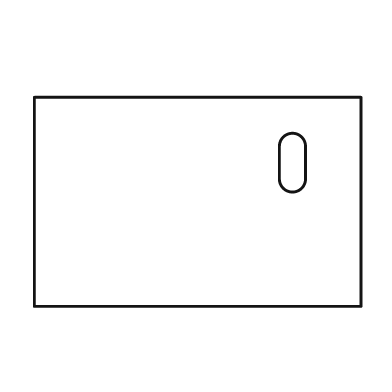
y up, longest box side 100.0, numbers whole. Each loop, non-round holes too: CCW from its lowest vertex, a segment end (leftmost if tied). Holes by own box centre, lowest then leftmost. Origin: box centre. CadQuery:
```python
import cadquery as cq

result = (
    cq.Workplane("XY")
    .moveTo(-50.0, -32.0)
    .lineTo(50.0, -32.0)
    .lineTo(50.0, 32.0)
    .lineTo(-50.0, 32.0)
    .close()
    .moveTo(25.0, 7.0)
    .threePointArc((29.0, 3.0), (33.0, 7.0))
    .lineTo(33.0, 17.0)
    .threePointArc((29.0, 21.0), (25.0, 17.0))
    .close()
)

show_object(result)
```